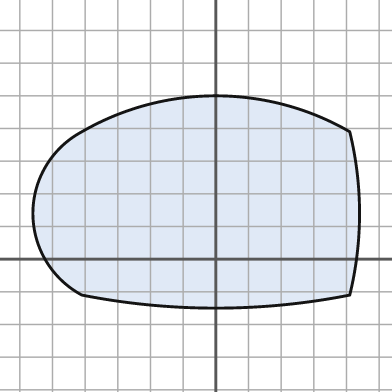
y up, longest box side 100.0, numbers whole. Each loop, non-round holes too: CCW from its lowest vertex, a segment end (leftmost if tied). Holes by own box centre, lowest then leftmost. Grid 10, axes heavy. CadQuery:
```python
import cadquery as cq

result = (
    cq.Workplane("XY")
    .moveTo(-41.0, -11.0)
    .threePointArc((0.0, -15.0), (41.0, -11.0))
    .threePointArc((44.0, 14.0), (41.0, 39.0))
    .threePointArc((0.0, 50.0), (-41.0, 39.0))
    .threePointArc((-56.0, 14.0), (-41.0, -11.0))
    .close()
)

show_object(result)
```